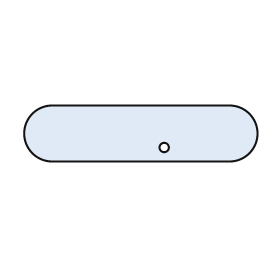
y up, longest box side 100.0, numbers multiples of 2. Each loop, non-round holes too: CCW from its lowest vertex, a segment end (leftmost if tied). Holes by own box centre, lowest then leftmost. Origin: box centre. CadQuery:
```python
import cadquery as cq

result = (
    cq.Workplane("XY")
    .moveTo(-38.0, -12.0)
    .lineTo(38.0, -12.0)
    .threePointArc((50.0, 0.0), (38.0, 12.0))
    .lineTo(-38.0, 12.0)
    .threePointArc((-50.0, 0.0), (-38.0, -12.0))
    .close()
    .moveTo(10.0, -6.0)
    .circle(2.0)
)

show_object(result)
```